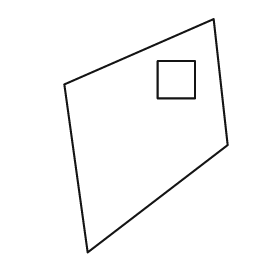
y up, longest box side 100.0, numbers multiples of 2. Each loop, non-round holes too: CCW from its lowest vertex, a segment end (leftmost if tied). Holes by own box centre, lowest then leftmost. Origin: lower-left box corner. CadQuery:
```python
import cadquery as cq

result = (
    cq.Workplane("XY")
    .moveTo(10.0, 0.0)
    .lineTo(70.0, 46.0)
    .lineTo(64.0, 100.0)
    .lineTo(0.0, 72.0)
    .close()
    .moveTo(40.0, 66.0)
    .lineTo(56.0, 66.0)
    .lineTo(56.0, 82.0)
    .lineTo(40.0, 82.0)
    .close()
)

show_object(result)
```